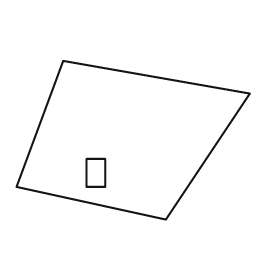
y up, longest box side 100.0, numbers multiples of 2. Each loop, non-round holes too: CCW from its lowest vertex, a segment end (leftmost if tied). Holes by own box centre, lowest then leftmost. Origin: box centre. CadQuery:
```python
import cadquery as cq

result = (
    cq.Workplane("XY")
    .moveTo(14.0, -34.0)
    .lineTo(50.0, 20.0)
    .lineTo(-30.0, 34.0)
    .lineTo(-50.0, -20.0)
    .close()
    .moveTo(-20.0, -20.0)
    .lineTo(-12.0, -20.0)
    .lineTo(-12.0, -8.0)
    .lineTo(-20.0, -8.0)
    .close()
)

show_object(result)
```